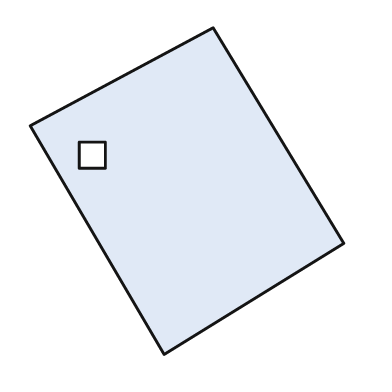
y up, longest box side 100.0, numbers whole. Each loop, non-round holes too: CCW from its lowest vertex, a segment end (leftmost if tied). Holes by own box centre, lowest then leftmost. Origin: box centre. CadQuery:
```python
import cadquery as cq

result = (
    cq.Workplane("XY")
    .moveTo(-7.0, -50.0)
    .lineTo(48.0, -16.0)
    .lineTo(8.0, 50.0)
    .lineTo(-48.0, 20.0)
    .close()
    .moveTo(-33.0, 7.0)
    .lineTo(-25.0, 7.0)
    .lineTo(-25.0, 15.0)
    .lineTo(-33.0, 15.0)
    .close()
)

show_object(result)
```